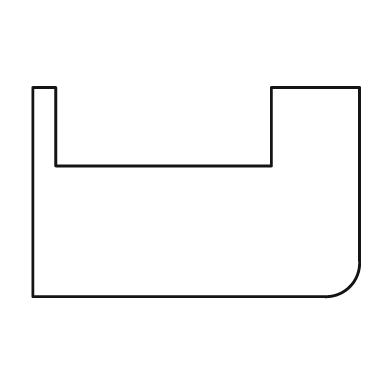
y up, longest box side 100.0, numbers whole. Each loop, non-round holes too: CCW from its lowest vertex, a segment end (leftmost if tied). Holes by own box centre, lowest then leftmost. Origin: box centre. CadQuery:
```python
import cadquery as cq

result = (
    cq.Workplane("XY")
    .moveTo(-50.0, -32.0)
    .lineTo(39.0, -32.0)
    .threePointArc((47.0, -29.0), (50.0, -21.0))
    .lineTo(50.0, 32.0)
    .lineTo(23.0, 32.0)
    .lineTo(23.0, 8.0)
    .lineTo(-43.0, 8.0)
    .lineTo(-43.0, 32.0)
    .lineTo(-50.0, 32.0)
    .close()
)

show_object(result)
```